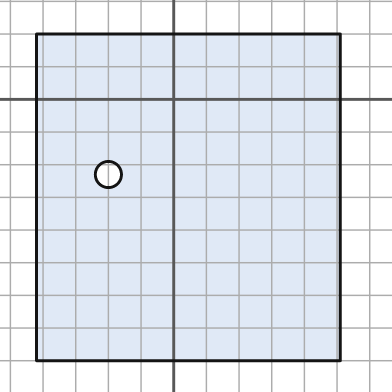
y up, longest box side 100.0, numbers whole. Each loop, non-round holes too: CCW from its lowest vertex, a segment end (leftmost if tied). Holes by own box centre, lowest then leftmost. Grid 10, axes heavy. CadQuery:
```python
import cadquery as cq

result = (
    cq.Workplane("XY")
    .moveTo(-42.0, -80.0)
    .lineTo(51.0, -80.0)
    .lineTo(51.0, 20.0)
    .lineTo(-42.0, 20.0)
    .close()
    .moveTo(-20.0, -23.0)
    .circle(4.0)
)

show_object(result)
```